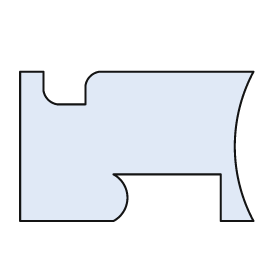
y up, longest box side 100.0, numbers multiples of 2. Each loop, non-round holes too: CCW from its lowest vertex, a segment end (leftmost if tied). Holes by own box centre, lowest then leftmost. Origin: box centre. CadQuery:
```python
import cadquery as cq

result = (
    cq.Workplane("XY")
    .moveTo(-50.0, -32.0)
    .lineTo(-10.0, -32.0)
    .threePointArc((-4.0, -22.0), (-10.0, -12.0))
    .lineTo(36.0, -12.0)
    .lineTo(36.0, -32.0)
    .lineTo(50.0, -32.0)
    .threePointArc((42.0, 0.0), (50.0, 32.0))
    .lineTo(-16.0, 32.0)
    .threePointArc((-20.0, 30.0), (-22.0, 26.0))
    .lineTo(-22.0, 18.0)
    .lineTo(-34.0, 18.0)
    .threePointArc((-38.0, 20.0), (-40.0, 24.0))
    .lineTo(-40.0, 32.0)
    .lineTo(-50.0, 32.0)
    .close()
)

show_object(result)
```